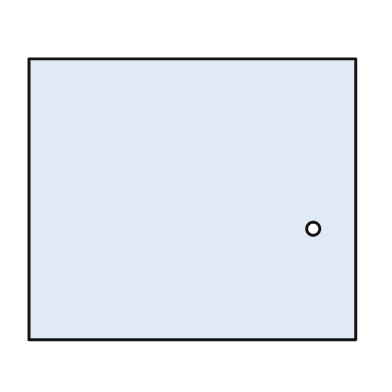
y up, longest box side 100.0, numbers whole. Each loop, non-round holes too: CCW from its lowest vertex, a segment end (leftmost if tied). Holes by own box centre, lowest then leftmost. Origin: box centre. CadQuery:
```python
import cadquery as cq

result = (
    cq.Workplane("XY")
    .moveTo(-50.0, -43.0)
    .lineTo(50.0, -43.0)
    .lineTo(50.0, 43.0)
    .lineTo(-50.0, 43.0)
    .close()
    .moveTo(37.0, -9.0)
    .circle(2.0)
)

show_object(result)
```